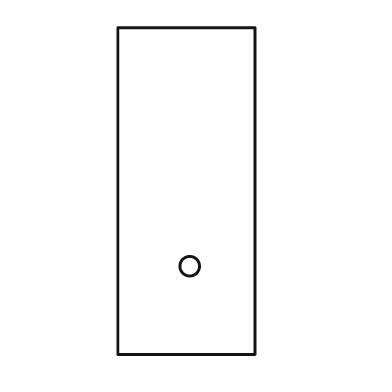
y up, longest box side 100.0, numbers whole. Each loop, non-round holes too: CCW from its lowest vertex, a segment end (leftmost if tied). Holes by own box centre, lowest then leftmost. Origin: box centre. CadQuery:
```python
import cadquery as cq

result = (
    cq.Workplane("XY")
    .moveTo(-21.0, -50.0)
    .lineTo(21.0, -50.0)
    .lineTo(21.0, 50.0)
    .lineTo(-21.0, 50.0)
    .close()
    .moveTo(1.0, -23.0)
    .circle(3.0)
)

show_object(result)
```